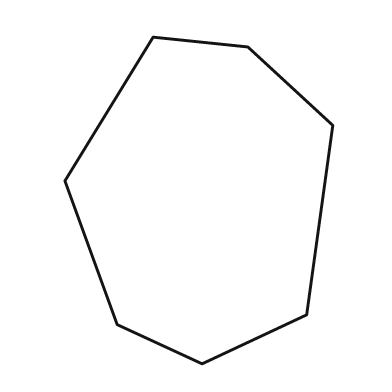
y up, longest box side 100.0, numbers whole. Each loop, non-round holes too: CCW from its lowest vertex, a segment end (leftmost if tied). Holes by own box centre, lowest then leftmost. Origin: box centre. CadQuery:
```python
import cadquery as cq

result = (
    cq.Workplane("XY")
    .moveTo(1.0, -50.0)
    .lineTo(33.0, -35.0)
    .lineTo(41.0, 23.0)
    .lineTo(15.0, 47.0)
    .lineTo(-14.0, 50.0)
    .lineTo(-41.0, 6.0)
    .lineTo(-25.0, -38.0)
    .close()
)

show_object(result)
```